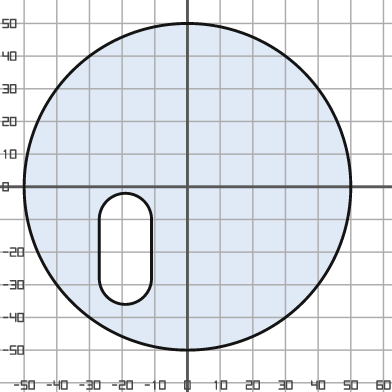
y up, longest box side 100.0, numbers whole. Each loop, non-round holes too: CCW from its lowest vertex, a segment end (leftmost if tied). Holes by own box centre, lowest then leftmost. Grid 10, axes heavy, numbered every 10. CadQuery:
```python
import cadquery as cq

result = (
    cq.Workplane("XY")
    .moveTo(0.0, 0.0)
    .circle(50.0)
    .moveTo(-27.0, -28.0)
    .threePointArc((-19.0, -36.0), (-11.0, -28.0))
    .lineTo(-11.0, -10.0)
    .threePointArc((-19.0, -2.0), (-27.0, -10.0))
    .close()
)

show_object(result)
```